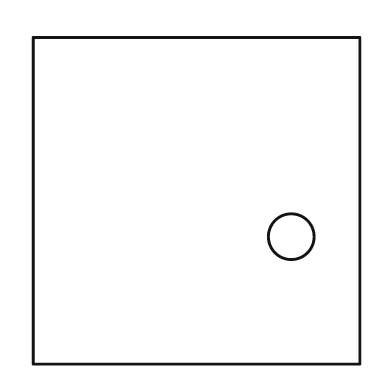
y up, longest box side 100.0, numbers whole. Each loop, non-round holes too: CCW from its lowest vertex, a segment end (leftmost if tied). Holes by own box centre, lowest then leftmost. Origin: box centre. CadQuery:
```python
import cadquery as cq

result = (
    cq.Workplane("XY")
    .moveTo(-50.0, -50.0)
    .lineTo(50.0, -50.0)
    .lineTo(50.0, 50.0)
    .lineTo(-50.0, 50.0)
    .close()
    .moveTo(29.0, -11.0)
    .circle(7.0)
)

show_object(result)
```